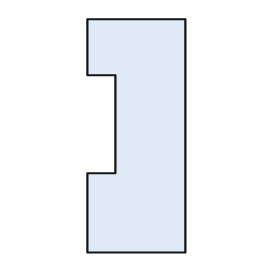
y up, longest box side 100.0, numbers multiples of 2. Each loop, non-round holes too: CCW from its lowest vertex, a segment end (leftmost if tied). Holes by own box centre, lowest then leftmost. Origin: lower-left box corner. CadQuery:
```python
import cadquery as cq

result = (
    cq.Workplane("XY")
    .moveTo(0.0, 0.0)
    .lineTo(42.0, 0.0)
    .lineTo(42.0, 100.0)
    .lineTo(0.0, 100.0)
    .lineTo(0.0, 76.0)
    .lineTo(12.0, 76.0)
    .lineTo(12.0, 34.0)
    .lineTo(0.0, 34.0)
    .close()
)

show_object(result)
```